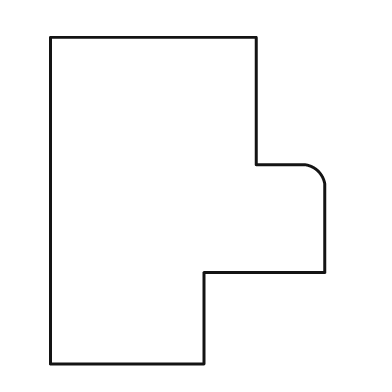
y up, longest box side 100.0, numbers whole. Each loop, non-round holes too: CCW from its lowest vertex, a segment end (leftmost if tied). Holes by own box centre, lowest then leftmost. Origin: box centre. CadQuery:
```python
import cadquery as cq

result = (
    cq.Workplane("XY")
    .moveTo(-42.0, -50.0)
    .lineTo(5.0, -50.0)
    .lineTo(5.0, -22.0)
    .lineTo(42.0, -22.0)
    .lineTo(42.0, 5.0)
    .threePointArc((40.0, 9.0), (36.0, 11.0))
    .lineTo(21.0, 11.0)
    .lineTo(21.0, 50.0)
    .lineTo(-42.0, 50.0)
    .close()
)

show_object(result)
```